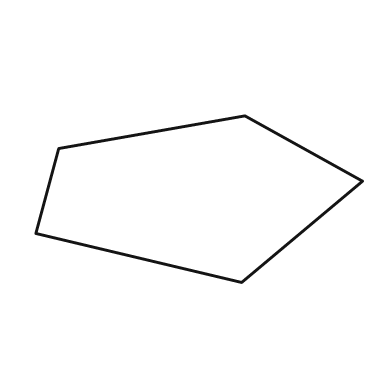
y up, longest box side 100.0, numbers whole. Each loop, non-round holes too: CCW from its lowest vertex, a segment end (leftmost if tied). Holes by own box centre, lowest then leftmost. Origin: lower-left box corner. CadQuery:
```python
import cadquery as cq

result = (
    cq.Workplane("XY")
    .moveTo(63.0, 0.0)
    .lineTo(100.0, 31.0)
    .lineTo(64.0, 51.0)
    .lineTo(7.0, 41.0)
    .lineTo(0.0, 15.0)
    .close()
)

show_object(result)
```